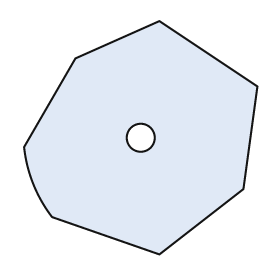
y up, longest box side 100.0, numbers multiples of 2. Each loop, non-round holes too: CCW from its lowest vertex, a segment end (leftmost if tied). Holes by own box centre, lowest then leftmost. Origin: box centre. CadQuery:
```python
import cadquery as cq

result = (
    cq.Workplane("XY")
    .moveTo(8.0, -50.0)
    .lineTo(44.0, -22.0)
    .lineTo(50.0, 22.0)
    .lineTo(8.0, 50.0)
    .lineTo(-28.0, 34.0)
    .lineTo(-50.0, -4.0)
    .threePointArc((-46.0, -20.0), (-38.0, -34.0))
    .close()
    .moveTo(0.0, 0.0)
    .circle(6.0)
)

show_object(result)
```